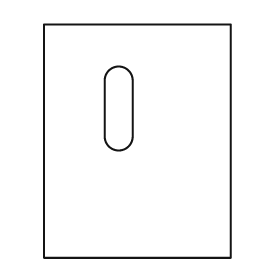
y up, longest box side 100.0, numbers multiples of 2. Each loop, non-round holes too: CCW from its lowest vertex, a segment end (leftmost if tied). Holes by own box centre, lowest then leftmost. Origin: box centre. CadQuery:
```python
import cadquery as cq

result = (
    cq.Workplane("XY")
    .moveTo(-40.0, -50.0)
    .lineTo(40.0, -50.0)
    .lineTo(40.0, 50.0)
    .lineTo(-40.0, 50.0)
    .close()
    .moveTo(-14.0, 2.0)
    .threePointArc((-8.0, -4.0), (-2.0, 2.0))
    .lineTo(-2.0, 26.0)
    .threePointArc((-8.0, 32.0), (-14.0, 26.0))
    .close()
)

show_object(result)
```